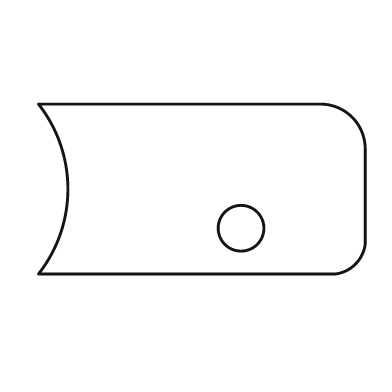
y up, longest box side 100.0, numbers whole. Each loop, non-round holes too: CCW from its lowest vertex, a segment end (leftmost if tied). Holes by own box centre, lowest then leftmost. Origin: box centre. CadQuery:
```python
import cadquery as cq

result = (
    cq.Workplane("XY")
    .moveTo(-50.0, -26.0)
    .lineTo(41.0, -26.0)
    .threePointArc((47.0, -23.0), (50.0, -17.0))
    .lineTo(50.0, 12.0)
    .threePointArc((46.0, 22.0), (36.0, 26.0))
    .lineTo(-50.0, 26.0)
    .threePointArc((-41.0, 0.0), (-50.0, -26.0))
    .close()
    .moveTo(12.0, -12.0)
    .circle(7.0)
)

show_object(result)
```